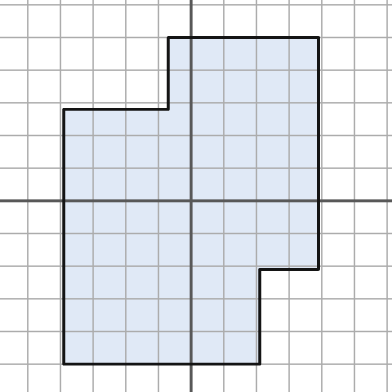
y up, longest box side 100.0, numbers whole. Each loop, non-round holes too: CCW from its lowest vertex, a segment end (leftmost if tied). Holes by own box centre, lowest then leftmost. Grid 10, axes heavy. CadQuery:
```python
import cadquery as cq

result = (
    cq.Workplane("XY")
    .moveTo(-39.0, -50.0)
    .lineTo(21.0, -50.0)
    .lineTo(21.0, -21.0)
    .lineTo(39.0, -21.0)
    .lineTo(39.0, 50.0)
    .lineTo(-7.0, 50.0)
    .lineTo(-7.0, 28.0)
    .lineTo(-39.0, 28.0)
    .close()
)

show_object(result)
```